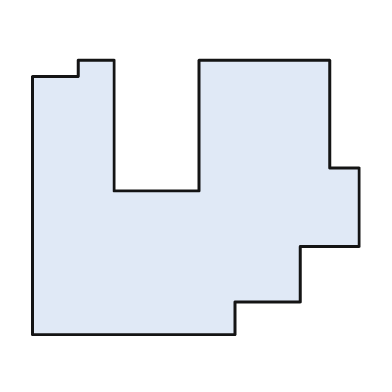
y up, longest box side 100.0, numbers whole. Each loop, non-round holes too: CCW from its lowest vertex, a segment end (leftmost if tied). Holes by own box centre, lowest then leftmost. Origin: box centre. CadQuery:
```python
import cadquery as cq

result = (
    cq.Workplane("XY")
    .moveTo(-50.0, -42.0)
    .lineTo(12.0, -42.0)
    .lineTo(12.0, -32.0)
    .lineTo(32.0, -32.0)
    .lineTo(32.0, -15.0)
    .lineTo(50.0, -15.0)
    .lineTo(50.0, 9.0)
    .lineTo(41.0, 9.0)
    .lineTo(41.0, 42.0)
    .lineTo(1.0, 42.0)
    .lineTo(1.0, 2.0)
    .lineTo(-25.0, 2.0)
    .lineTo(-25.0, 42.0)
    .lineTo(-36.0, 42.0)
    .lineTo(-36.0, 37.0)
    .lineTo(-50.0, 37.0)
    .close()
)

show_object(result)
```